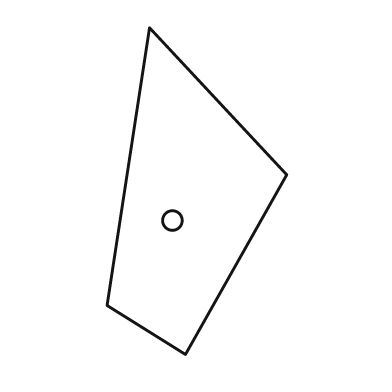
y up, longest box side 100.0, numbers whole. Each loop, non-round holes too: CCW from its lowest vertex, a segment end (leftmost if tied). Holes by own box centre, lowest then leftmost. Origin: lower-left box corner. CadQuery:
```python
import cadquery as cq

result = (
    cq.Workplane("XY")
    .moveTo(24.0, 0.0)
    .lineTo(55.0, 55.0)
    .lineTo(13.0, 100.0)
    .lineTo(0.0, 15.0)
    .close()
    .moveTo(20.0, 41.0)
    .circle(3.0)
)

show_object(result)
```